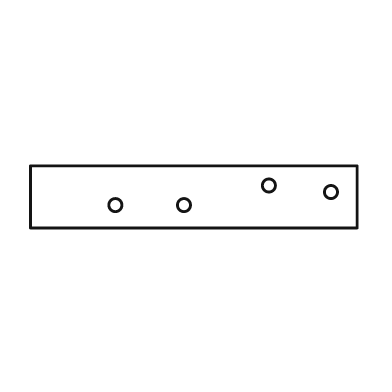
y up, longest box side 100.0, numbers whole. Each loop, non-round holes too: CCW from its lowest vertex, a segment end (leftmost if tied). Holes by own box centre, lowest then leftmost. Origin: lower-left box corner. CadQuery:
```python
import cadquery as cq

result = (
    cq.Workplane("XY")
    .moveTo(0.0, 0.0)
    .lineTo(100.0, 0.0)
    .lineTo(100.0, 19.0)
    .lineTo(0.0, 19.0)
    .close()
    .moveTo(26.0, 7.0)
    .circle(2.0)
    .moveTo(47.0, 7.0)
    .circle(2.0)
    .moveTo(92.0, 11.0)
    .circle(2.0)
    .moveTo(73.0, 13.0)
    .circle(2.0)
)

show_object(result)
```